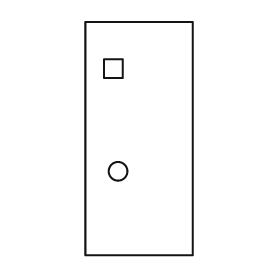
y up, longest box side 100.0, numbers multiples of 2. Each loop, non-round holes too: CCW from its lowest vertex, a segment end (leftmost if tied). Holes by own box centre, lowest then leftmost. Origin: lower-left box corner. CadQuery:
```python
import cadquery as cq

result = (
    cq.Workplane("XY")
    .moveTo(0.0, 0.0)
    .lineTo(46.0, 0.0)
    .lineTo(46.0, 100.0)
    .lineTo(0.0, 100.0)
    .close()
    .moveTo(14.0, 36.0)
    .circle(4.0)
    .moveTo(8.0, 76.0)
    .lineTo(16.0, 76.0)
    .lineTo(16.0, 84.0)
    .lineTo(8.0, 84.0)
    .close()
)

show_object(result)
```